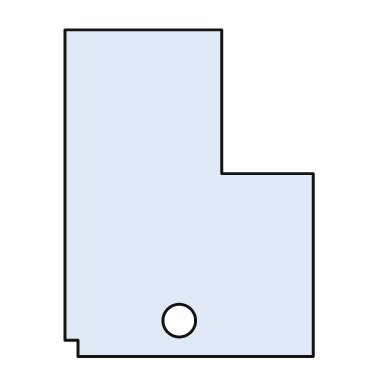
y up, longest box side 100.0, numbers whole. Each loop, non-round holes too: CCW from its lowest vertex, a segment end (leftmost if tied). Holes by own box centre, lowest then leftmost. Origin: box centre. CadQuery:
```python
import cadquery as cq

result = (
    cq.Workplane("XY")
    .moveTo(-34.0, -50.0)
    .lineTo(38.0, -50.0)
    .lineTo(38.0, 6.0)
    .lineTo(10.0, 6.0)
    .lineTo(10.0, 50.0)
    .lineTo(-38.0, 50.0)
    .lineTo(-38.0, -45.0)
    .lineTo(-34.0, -45.0)
    .close()
    .moveTo(-3.0, -39.0)
    .circle(5.0)
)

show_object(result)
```